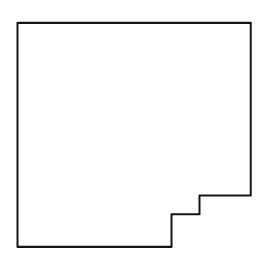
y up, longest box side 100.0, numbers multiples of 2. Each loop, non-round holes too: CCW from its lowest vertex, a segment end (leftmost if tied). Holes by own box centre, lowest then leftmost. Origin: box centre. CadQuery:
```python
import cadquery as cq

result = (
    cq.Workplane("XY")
    .moveTo(-50.0, -48.0)
    .lineTo(16.0, -48.0)
    .lineTo(16.0, -34.0)
    .lineTo(28.0, -34.0)
    .lineTo(28.0, -26.0)
    .lineTo(50.0, -26.0)
    .lineTo(50.0, 48.0)
    .lineTo(-50.0, 48.0)
    .close()
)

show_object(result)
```